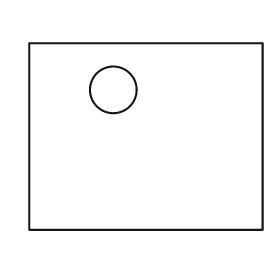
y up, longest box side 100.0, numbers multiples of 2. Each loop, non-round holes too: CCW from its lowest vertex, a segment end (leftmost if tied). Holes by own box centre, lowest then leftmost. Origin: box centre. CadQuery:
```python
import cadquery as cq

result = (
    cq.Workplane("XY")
    .moveTo(-50.0, -40.0)
    .lineTo(50.0, -40.0)
    .lineTo(50.0, 40.0)
    .lineTo(-50.0, 40.0)
    .close()
    .moveTo(-14.0, 20.0)
    .circle(10.0)
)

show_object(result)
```